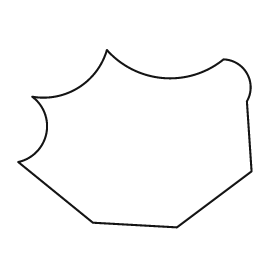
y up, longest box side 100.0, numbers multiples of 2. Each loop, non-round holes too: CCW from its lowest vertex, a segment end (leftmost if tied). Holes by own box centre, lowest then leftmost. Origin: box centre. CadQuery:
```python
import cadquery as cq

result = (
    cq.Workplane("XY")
    .moveTo(18.0, -38.0)
    .lineTo(50.0, -14.0)
    .lineTo(48.0, 16.0)
    .threePointArc((48.0, 28.0), (38.0, 34.0))
    .threePointArc((12.0, 26.0), (-12.0, 38.0))
    .threePointArc((-24.0, 22.0), (-44.0, 18.0))
    .threePointArc((-38.0, 2.0), (-50.0, -10.0))
    .lineTo(-18.0, -36.0)
    .close()
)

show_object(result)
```